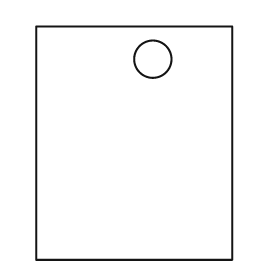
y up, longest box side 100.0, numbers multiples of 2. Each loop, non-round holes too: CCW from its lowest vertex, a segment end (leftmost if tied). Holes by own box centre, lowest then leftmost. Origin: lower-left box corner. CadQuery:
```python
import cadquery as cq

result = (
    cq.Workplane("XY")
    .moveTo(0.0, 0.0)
    .lineTo(84.0, 0.0)
    .lineTo(84.0, 100.0)
    .lineTo(0.0, 100.0)
    .close()
    .moveTo(50.0, 86.0)
    .circle(8.0)
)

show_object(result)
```